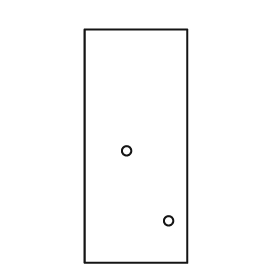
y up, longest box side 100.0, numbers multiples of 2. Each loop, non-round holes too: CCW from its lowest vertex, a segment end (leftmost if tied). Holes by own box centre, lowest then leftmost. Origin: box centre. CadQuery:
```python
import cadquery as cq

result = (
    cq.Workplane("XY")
    .moveTo(-22.0, -50.0)
    .lineTo(22.0, -50.0)
    .lineTo(22.0, 50.0)
    .lineTo(-22.0, 50.0)
    .close()
    .moveTo(14.0, -32.0)
    .circle(2.0)
    .moveTo(-4.0, -2.0)
    .circle(2.0)
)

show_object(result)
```